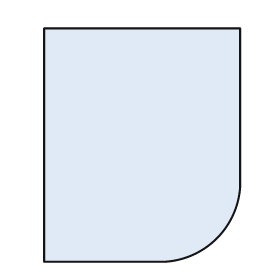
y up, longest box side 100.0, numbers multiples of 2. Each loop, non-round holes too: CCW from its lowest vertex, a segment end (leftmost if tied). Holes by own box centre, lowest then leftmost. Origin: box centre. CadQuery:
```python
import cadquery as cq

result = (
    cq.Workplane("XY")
    .moveTo(-42.0, -50.0)
    .lineTo(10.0, -50.0)
    .threePointArc((32.0, -40.0), (42.0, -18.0))
    .lineTo(42.0, 50.0)
    .lineTo(-42.0, 50.0)
    .close()
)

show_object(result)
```